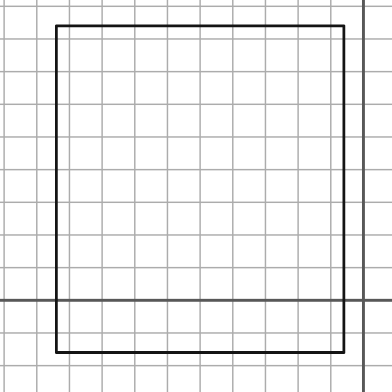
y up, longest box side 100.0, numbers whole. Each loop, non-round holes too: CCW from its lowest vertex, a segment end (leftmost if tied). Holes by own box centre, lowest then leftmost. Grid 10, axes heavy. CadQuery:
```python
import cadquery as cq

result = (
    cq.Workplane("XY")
    .moveTo(-94.0, -16.0)
    .lineTo(-6.0, -16.0)
    .lineTo(-6.0, 84.0)
    .lineTo(-94.0, 84.0)
    .close()
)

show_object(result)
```